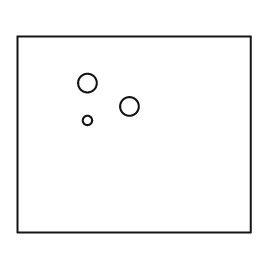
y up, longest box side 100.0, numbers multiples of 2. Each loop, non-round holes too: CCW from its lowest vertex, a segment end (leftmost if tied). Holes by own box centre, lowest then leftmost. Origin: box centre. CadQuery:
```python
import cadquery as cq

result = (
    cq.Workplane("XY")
    .moveTo(-50.0, -42.0)
    .lineTo(50.0, -42.0)
    .lineTo(50.0, 42.0)
    .lineTo(-50.0, 42.0)
    .close()
    .moveTo(-20.0, 6.0)
    .circle(2.0)
    .moveTo(-2.0, 12.0)
    .circle(4.0)
    .moveTo(-20.0, 22.0)
    .circle(4.0)
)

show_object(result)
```